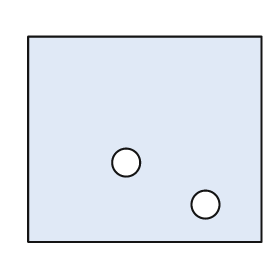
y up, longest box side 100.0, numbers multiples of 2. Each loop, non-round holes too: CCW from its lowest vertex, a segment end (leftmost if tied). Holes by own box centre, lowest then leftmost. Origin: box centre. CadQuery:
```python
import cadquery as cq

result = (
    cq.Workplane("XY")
    .moveTo(-50.0, -44.0)
    .lineTo(50.0, -44.0)
    .lineTo(50.0, 44.0)
    .lineTo(-50.0, 44.0)
    .close()
    .moveTo(26.0, -28.0)
    .circle(6.0)
    .moveTo(-8.0, -10.0)
    .circle(6.0)
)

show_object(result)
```